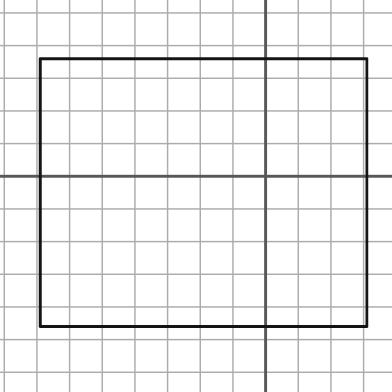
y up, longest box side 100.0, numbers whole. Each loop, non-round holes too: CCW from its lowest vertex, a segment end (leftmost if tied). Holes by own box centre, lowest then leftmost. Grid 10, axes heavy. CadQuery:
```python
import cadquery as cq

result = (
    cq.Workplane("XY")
    .moveTo(-69.0, -46.0)
    .lineTo(31.0, -46.0)
    .lineTo(31.0, 36.0)
    .lineTo(-69.0, 36.0)
    .close()
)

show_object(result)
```